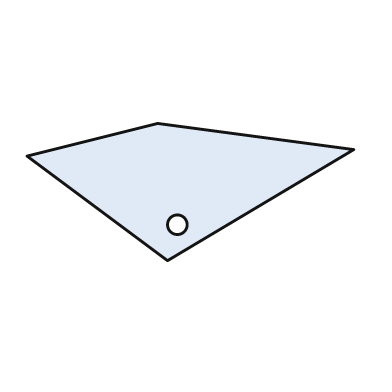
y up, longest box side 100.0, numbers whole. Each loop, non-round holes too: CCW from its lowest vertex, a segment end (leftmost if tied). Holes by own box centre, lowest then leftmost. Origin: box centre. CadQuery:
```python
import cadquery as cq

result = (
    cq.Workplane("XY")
    .moveTo(-7.0, -21.0)
    .lineTo(50.0, 13.0)
    .lineTo(-10.0, 21.0)
    .lineTo(-50.0, 11.0)
    .close()
    .moveTo(-4.0, -10.0)
    .circle(3.0)
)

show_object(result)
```